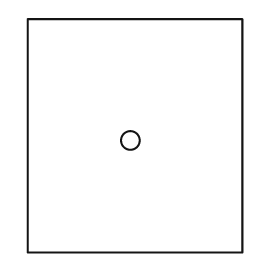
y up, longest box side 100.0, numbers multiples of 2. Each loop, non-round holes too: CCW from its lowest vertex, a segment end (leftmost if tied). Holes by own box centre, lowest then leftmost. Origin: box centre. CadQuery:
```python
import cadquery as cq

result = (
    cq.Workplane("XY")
    .moveTo(-46.0, -50.0)
    .lineTo(46.0, -50.0)
    .lineTo(46.0, 50.0)
    .lineTo(-46.0, 50.0)
    .close()
    .moveTo(-2.0, -2.0)
    .circle(4.0)
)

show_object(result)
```